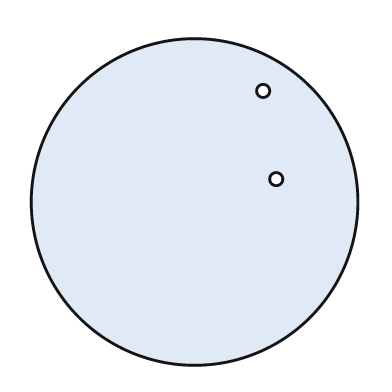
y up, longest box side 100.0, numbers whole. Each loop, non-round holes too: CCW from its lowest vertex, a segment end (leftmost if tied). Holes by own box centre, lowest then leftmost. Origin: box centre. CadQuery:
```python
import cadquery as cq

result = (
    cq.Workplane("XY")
    .moveTo(0.0, 0.0)
    .circle(50.0)
    .moveTo(25.0, 7.0)
    .circle(2.0)
    .moveTo(21.0, 34.0)
    .circle(2.0)
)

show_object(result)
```